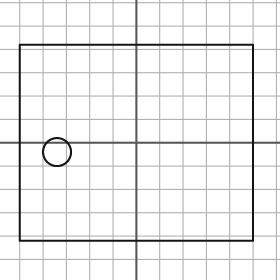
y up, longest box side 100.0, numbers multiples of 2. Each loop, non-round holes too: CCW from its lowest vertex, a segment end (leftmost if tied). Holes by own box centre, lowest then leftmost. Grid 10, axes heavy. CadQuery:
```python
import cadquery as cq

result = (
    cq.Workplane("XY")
    .moveTo(-50.0, -42.0)
    .lineTo(50.0, -42.0)
    .lineTo(50.0, 42.0)
    .lineTo(-50.0, 42.0)
    .close()
    .moveTo(-34.0, -4.0)
    .circle(6.0)
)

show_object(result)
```